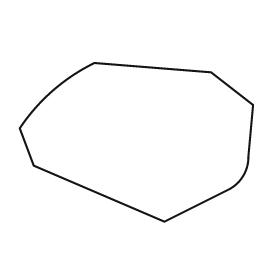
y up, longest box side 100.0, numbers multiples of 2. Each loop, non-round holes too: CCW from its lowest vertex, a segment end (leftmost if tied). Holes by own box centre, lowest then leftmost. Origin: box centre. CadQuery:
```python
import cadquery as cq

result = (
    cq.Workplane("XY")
    .moveTo(12.0, -34.0)
    .lineTo(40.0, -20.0)
    .threePointArc((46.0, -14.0), (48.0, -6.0))
    .lineTo(50.0, 16.0)
    .lineTo(32.0, 30.0)
    .lineTo(-18.0, 34.0)
    .threePointArc((-36.0, 22.0), (-50.0, 6.0))
    .lineTo(-44.0, -10.0)
    .close()
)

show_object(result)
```